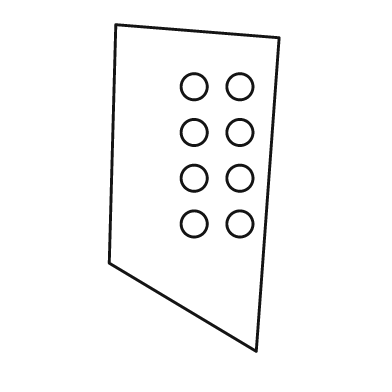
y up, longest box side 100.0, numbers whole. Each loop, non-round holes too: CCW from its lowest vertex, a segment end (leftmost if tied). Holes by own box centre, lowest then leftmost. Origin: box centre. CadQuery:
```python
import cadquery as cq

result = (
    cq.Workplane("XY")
    .moveTo(19.0, -50.0)
    .lineTo(26.0, 46.0)
    .lineTo(-24.0, 50.0)
    .lineTo(-26.0, -23.0)
    .close()
    .moveTo(0.0, -11.0)
    .circle(4.0)
    .moveTo(14.0, -11.0)
    .circle(4.0)
    .moveTo(0.0, 3.0)
    .circle(4.0)
    .moveTo(14.0, 3.0)
    .circle(4.0)
    .moveTo(0.0, 17.0)
    .circle(4.0)
    .moveTo(14.0, 17.0)
    .circle(4.0)
    .moveTo(0.0, 31.0)
    .circle(4.0)
    .moveTo(14.0, 31.0)
    .circle(4.0)
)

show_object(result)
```